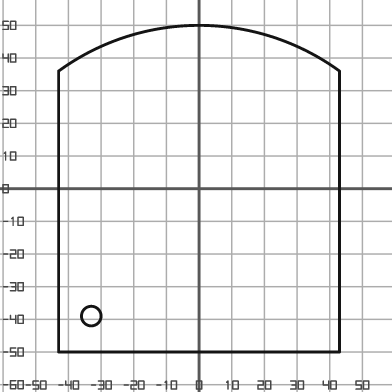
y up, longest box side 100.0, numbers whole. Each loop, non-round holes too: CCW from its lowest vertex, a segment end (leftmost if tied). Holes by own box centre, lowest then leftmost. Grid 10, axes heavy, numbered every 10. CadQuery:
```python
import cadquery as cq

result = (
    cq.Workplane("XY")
    .moveTo(-43.0, -50.0)
    .lineTo(43.0, -50.0)
    .lineTo(43.0, 36.0)
    .threePointArc((0.0, 50.0), (-43.0, 36.0))
    .close()
    .moveTo(-33.0, -39.0)
    .circle(3.0)
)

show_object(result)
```